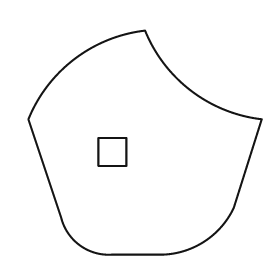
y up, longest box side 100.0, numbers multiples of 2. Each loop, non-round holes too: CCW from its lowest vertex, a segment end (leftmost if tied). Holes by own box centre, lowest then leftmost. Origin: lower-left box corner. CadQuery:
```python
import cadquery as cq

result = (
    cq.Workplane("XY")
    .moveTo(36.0, 0.0)
    .lineTo(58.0, 0.0)
    .threePointArc((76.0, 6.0), (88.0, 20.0))
    .lineTo(100.0, 58.0)
    .threePointArc((70.0, 70.0), (50.0, 96.0))
    .threePointArc((20.0, 84.0), (0.0, 58.0))
    .lineTo(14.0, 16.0)
    .threePointArc((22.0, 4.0), (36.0, 0.0))
    .close()
    .moveTo(30.0, 38.0)
    .lineTo(42.0, 38.0)
    .lineTo(42.0, 50.0)
    .lineTo(30.0, 50.0)
    .close()
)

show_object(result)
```